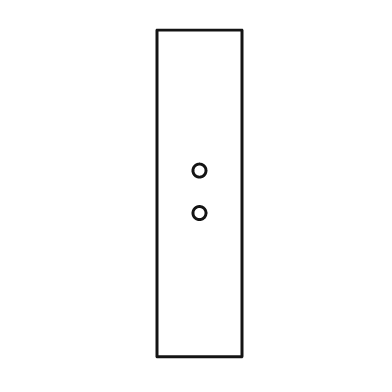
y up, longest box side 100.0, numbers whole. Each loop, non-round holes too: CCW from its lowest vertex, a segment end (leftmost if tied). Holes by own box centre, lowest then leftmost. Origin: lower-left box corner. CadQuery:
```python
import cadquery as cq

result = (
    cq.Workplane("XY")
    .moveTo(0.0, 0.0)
    .lineTo(26.0, 0.0)
    .lineTo(26.0, 100.0)
    .lineTo(0.0, 100.0)
    .close()
    .moveTo(13.0, 44.0)
    .circle(2.0)
    .moveTo(13.0, 57.0)
    .circle(2.0)
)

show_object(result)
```